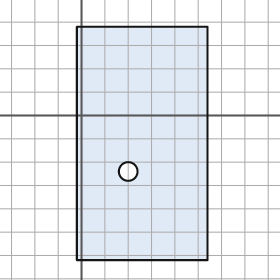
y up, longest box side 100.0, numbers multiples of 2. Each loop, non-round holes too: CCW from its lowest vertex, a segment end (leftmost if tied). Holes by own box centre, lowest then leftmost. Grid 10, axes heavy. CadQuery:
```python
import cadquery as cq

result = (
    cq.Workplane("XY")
    .moveTo(-2.0, -62.0)
    .lineTo(54.0, -62.0)
    .lineTo(54.0, 38.0)
    .lineTo(-2.0, 38.0)
    .close()
    .moveTo(20.0, -24.0)
    .circle(4.0)
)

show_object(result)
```